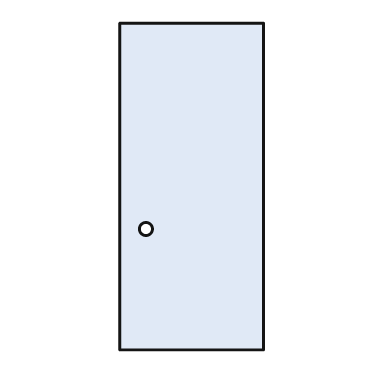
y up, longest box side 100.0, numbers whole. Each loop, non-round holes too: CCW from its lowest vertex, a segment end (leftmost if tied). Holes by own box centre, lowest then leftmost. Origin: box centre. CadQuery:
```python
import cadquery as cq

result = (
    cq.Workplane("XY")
    .moveTo(-22.0, -50.0)
    .lineTo(22.0, -50.0)
    .lineTo(22.0, 50.0)
    .lineTo(-22.0, 50.0)
    .close()
    .moveTo(-14.0, -13.0)
    .circle(2.0)
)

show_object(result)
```